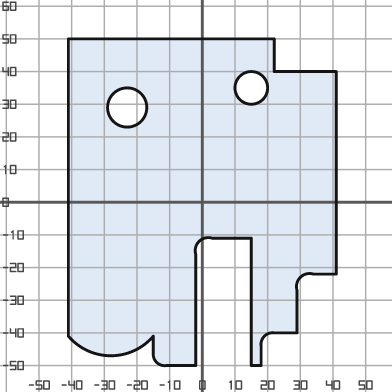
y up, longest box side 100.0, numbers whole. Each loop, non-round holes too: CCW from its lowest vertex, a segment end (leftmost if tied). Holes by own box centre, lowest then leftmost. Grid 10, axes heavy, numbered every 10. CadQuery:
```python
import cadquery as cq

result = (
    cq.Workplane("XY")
    .moveTo(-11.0, -50.0)
    .lineTo(-2.0, -50.0)
    .lineTo(-2.0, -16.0)
    .threePointArc((-1.0, -12.0), (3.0, -11.0))
    .lineTo(15.0, -11.0)
    .lineTo(15.0, -50.0)
    .lineTo(18.0, -50.0)
    .lineTo(18.0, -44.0)
    .threePointArc((19.0, -41.0), (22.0, -40.0))
    .lineTo(29.0, -40.0)
    .lineTo(29.0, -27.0)
    .threePointArc((30.0, -23.0), (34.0, -22.0))
    .lineTo(41.0, -22.0)
    .lineTo(41.0, 40.0)
    .lineTo(22.0, 40.0)
    .lineTo(22.0, 50.0)
    .lineTo(-41.0, 50.0)
    .lineTo(-41.0, -41.0)
    .threePointArc((-28.0, -47.0), (-15.0, -41.0))
    .lineTo(-15.0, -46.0)
    .threePointArc((-14.0, -49.0), (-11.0, -50.0))
    .close()
    .moveTo(-23.0, 29.0)
    .circle(6.0)
    .moveTo(15.0, 35.0)
    .circle(5.0)
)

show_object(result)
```